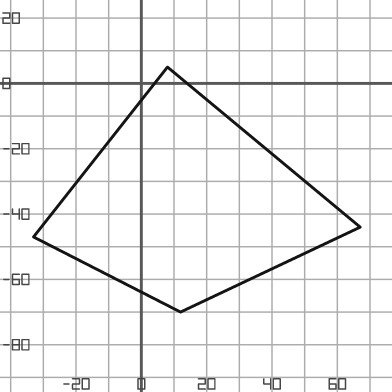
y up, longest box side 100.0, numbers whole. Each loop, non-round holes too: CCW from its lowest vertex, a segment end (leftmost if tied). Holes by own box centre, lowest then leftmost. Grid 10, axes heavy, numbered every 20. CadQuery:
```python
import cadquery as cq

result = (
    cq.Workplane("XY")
    .moveTo(12.0, -70.0)
    .lineTo(67.0, -44.0)
    .lineTo(8.0, 5.0)
    .lineTo(-33.0, -47.0)
    .close()
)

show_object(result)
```